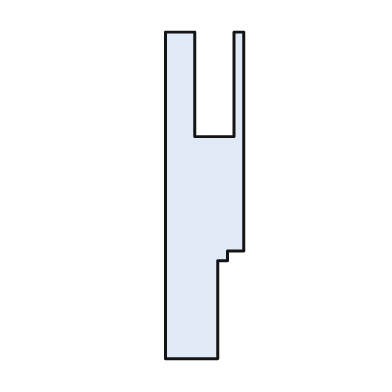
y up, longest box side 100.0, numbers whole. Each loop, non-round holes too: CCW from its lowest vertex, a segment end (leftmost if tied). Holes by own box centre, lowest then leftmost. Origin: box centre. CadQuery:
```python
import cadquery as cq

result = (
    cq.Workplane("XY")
    .moveTo(-12.0, -50.0)
    .lineTo(4.0, -50.0)
    .lineTo(4.0, -20.0)
    .lineTo(7.0, -20.0)
    .lineTo(7.0, -17.0)
    .lineTo(12.0, -17.0)
    .lineTo(12.0, 50.0)
    .lineTo(9.0, 50.0)
    .lineTo(9.0, 18.0)
    .lineTo(-3.0, 18.0)
    .lineTo(-3.0, 50.0)
    .lineTo(-12.0, 50.0)
    .close()
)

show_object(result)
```